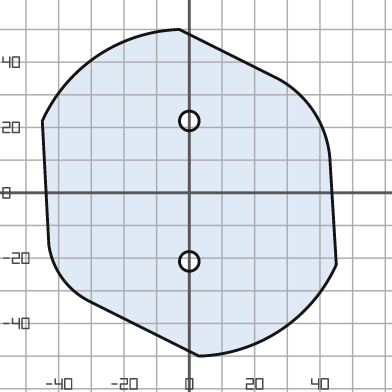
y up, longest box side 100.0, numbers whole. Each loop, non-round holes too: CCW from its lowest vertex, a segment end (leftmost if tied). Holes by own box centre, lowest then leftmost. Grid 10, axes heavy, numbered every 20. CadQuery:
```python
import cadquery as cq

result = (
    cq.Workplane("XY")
    .moveTo(3.0, -50.0)
    .threePointArc((28.0, -42.0), (45.0, -22.0))
    .lineTo(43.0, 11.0)
    .threePointArc((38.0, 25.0), (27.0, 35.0))
    .lineTo(-3.0, 50.0)
    .threePointArc((-28.0, 42.0), (-45.0, 22.0))
    .lineTo(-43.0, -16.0)
    .threePointArc((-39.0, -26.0), (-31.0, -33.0))
    .close()
    .moveTo(0.0, -21.0)
    .circle(3.0)
    .moveTo(0.0, 22.0)
    .circle(3.0)
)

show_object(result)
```